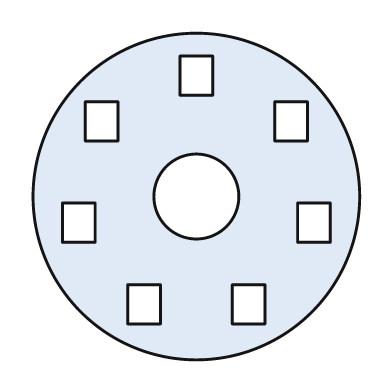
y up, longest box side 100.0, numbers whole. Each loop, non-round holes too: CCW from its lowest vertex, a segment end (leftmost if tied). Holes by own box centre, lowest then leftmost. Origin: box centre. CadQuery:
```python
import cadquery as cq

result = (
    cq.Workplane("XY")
    .moveTo(0.0, 0.0)
    .circle(50.0)
    .moveTo(-21.0, -39.0)
    .lineTo(-11.0, -39.0)
    .lineTo(-11.0, -27.0)
    .lineTo(-21.0, -27.0)
    .close()
    .moveTo(11.0, -39.0)
    .lineTo(21.0, -39.0)
    .lineTo(21.0, -27.0)
    .lineTo(11.0, -27.0)
    .close()
    .moveTo(-41.0, -14.0)
    .lineTo(-31.0, -14.0)
    .lineTo(-31.0, -2.0)
    .lineTo(-41.0, -2.0)
    .close()
    .moveTo(31.0, -14.0)
    .lineTo(41.0, -14.0)
    .lineTo(41.0, -2.0)
    .lineTo(31.0, -2.0)
    .close()
    .moveTo(0.0, 0.0)
    .circle(13.0)
    .moveTo(-34.0, 17.0)
    .lineTo(-24.0, 17.0)
    .lineTo(-24.0, 29.0)
    .lineTo(-34.0, 29.0)
    .close()
    .moveTo(24.0, 17.0)
    .lineTo(34.0, 17.0)
    .lineTo(34.0, 29.0)
    .lineTo(24.0, 29.0)
    .close()
    .moveTo(-5.0, 31.0)
    .lineTo(5.0, 31.0)
    .lineTo(5.0, 43.0)
    .lineTo(-5.0, 43.0)
    .close()
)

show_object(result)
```